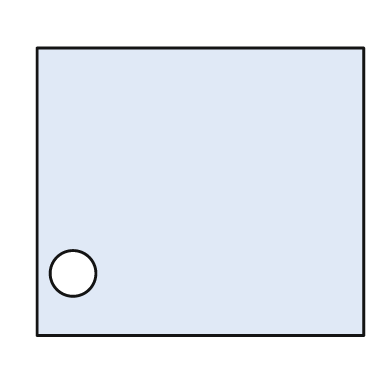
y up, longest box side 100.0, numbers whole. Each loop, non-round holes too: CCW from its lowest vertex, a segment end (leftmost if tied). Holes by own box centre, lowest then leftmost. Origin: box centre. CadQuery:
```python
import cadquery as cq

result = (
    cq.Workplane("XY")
    .moveTo(-50.0, -44.0)
    .lineTo(50.0, -44.0)
    .lineTo(50.0, 44.0)
    .lineTo(-50.0, 44.0)
    .close()
    .moveTo(-39.0, -25.0)
    .circle(7.0)
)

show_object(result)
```